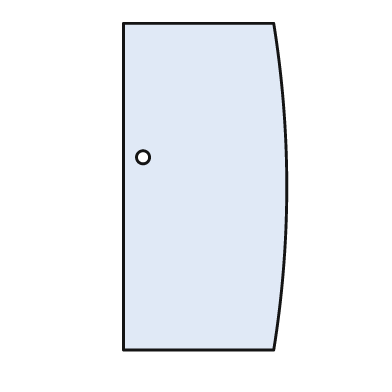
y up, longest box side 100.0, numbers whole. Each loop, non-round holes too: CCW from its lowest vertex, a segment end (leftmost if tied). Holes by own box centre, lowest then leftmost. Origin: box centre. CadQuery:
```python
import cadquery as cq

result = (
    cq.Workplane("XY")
    .moveTo(-25.0, -50.0)
    .lineTo(21.0, -50.0)
    .threePointArc((25.0, 0.0), (21.0, 50.0))
    .lineTo(-25.0, 50.0)
    .close()
    .moveTo(-19.0, 9.0)
    .circle(2.0)
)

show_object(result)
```